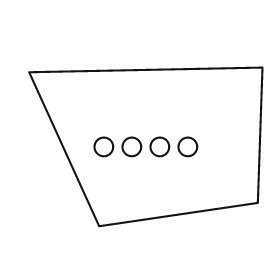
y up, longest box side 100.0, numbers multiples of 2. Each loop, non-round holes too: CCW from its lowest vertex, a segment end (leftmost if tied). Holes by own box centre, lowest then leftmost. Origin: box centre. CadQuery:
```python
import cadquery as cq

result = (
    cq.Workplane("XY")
    .moveTo(-20.0, -34.0)
    .lineTo(48.0, -24.0)
    .lineTo(50.0, 34.0)
    .lineTo(-50.0, 32.0)
    .close()
    .moveTo(-18.0, 0.0)
    .circle(4.0)
    .moveTo(-6.0, 0.0)
    .circle(4.0)
    .moveTo(6.0, 0.0)
    .circle(4.0)
    .moveTo(18.0, 0.0)
    .circle(4.0)
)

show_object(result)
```